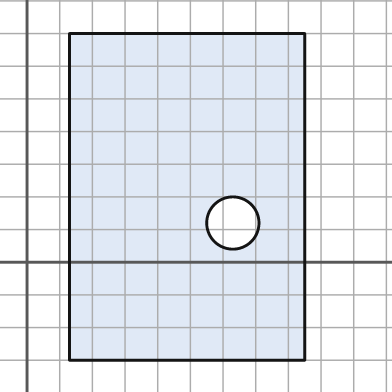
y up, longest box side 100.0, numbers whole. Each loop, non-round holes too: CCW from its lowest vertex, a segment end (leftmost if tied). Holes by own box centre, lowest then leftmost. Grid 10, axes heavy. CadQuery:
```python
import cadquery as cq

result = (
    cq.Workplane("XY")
    .moveTo(13.0, -30.0)
    .lineTo(85.0, -30.0)
    .lineTo(85.0, 70.0)
    .lineTo(13.0, 70.0)
    .close()
    .moveTo(63.0, 12.0)
    .circle(8.0)
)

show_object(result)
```